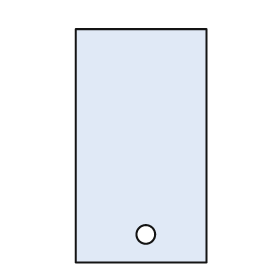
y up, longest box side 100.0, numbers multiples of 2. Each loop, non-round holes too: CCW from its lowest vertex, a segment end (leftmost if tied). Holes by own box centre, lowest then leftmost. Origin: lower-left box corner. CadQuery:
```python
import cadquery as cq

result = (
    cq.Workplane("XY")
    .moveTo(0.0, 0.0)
    .lineTo(56.0, 0.0)
    .lineTo(56.0, 100.0)
    .lineTo(0.0, 100.0)
    .close()
    .moveTo(30.0, 12.0)
    .circle(4.0)
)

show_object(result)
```